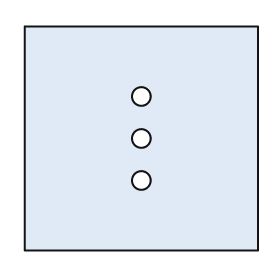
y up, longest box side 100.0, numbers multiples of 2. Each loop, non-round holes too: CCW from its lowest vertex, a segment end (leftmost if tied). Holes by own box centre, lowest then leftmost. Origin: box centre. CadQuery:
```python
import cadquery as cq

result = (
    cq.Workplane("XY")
    .moveTo(-50.0, -48.0)
    .lineTo(50.0, -48.0)
    .lineTo(50.0, 48.0)
    .lineTo(-50.0, 48.0)
    .close()
    .moveTo(0.0, -18.0)
    .circle(4.0)
    .moveTo(0.0, 0.0)
    .circle(4.0)
    .moveTo(0.0, 18.0)
    .circle(4.0)
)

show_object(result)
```